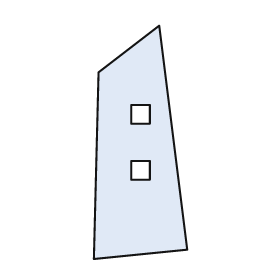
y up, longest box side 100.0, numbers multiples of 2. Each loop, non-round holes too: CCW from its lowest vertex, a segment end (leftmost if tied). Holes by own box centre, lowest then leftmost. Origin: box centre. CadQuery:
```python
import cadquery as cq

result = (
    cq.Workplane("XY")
    .moveTo(-20.0, -50.0)
    .lineTo(20.0, -46.0)
    .lineTo(8.0, 50.0)
    .lineTo(-18.0, 30.0)
    .close()
    .moveTo(-4.0, -16.0)
    .lineTo(4.0, -16.0)
    .lineTo(4.0, -8.0)
    .lineTo(-4.0, -8.0)
    .close()
    .moveTo(-4.0, 8.0)
    .lineTo(4.0, 8.0)
    .lineTo(4.0, 16.0)
    .lineTo(-4.0, 16.0)
    .close()
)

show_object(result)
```